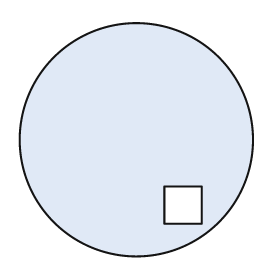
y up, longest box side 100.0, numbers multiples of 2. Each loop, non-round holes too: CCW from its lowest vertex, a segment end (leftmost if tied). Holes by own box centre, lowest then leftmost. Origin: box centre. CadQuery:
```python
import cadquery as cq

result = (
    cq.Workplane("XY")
    .moveTo(0.0, 0.0)
    .circle(50.0)
    .moveTo(12.0, -36.0)
    .lineTo(28.0, -36.0)
    .lineTo(28.0, -20.0)
    .lineTo(12.0, -20.0)
    .close()
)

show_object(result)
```